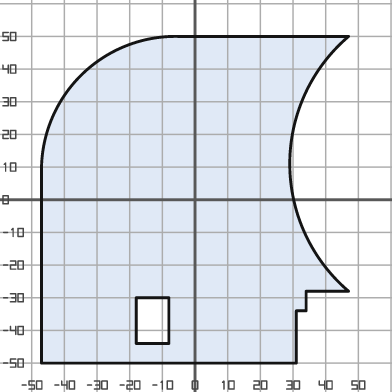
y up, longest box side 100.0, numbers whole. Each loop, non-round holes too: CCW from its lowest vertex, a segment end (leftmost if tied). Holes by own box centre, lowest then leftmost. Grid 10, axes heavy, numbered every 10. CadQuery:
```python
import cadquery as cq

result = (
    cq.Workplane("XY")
    .moveTo(-47.0, -50.0)
    .lineTo(31.0, -50.0)
    .lineTo(31.0, -34.0)
    .lineTo(34.0, -34.0)
    .lineTo(34.0, -28.0)
    .lineTo(47.0, -28.0)
    .threePointArc((29.0, 11.0), (47.0, 50.0))
    .lineTo(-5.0, 50.0)
    .threePointArc((-35.0, 38.0), (-47.0, 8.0))
    .close()
    .moveTo(-18.0, -44.0)
    .lineTo(-8.0, -44.0)
    .lineTo(-8.0, -30.0)
    .lineTo(-18.0, -30.0)
    .close()
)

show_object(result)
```